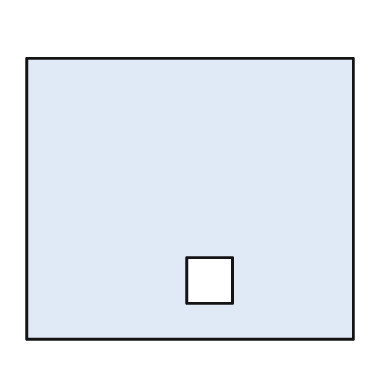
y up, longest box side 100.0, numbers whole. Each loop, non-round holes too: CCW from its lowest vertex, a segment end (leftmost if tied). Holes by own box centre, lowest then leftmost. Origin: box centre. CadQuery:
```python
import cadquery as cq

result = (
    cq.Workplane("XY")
    .moveTo(-50.0, -43.0)
    .lineTo(50.0, -43.0)
    .lineTo(50.0, 43.0)
    .lineTo(-50.0, 43.0)
    .close()
    .moveTo(-1.0, -32.0)
    .lineTo(13.0, -32.0)
    .lineTo(13.0, -18.0)
    .lineTo(-1.0, -18.0)
    .close()
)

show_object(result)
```